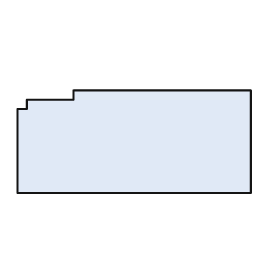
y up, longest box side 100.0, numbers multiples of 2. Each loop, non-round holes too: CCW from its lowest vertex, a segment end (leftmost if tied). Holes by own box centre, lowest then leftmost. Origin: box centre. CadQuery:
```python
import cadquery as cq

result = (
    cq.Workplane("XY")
    .moveTo(-50.0, -22.0)
    .lineTo(50.0, -22.0)
    .lineTo(50.0, 22.0)
    .lineTo(-26.0, 22.0)
    .lineTo(-26.0, 18.0)
    .lineTo(-46.0, 18.0)
    .lineTo(-46.0, 14.0)
    .lineTo(-50.0, 14.0)
    .close()
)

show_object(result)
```